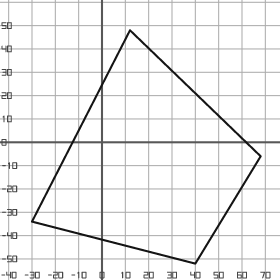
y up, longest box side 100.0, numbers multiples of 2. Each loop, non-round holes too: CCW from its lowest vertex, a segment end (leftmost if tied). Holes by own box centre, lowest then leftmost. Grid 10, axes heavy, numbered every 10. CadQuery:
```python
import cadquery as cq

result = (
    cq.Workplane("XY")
    .moveTo(40.0, -52.0)
    .lineTo(68.0, -6.0)
    .lineTo(12.0, 48.0)
    .lineTo(-30.0, -34.0)
    .close()
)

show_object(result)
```